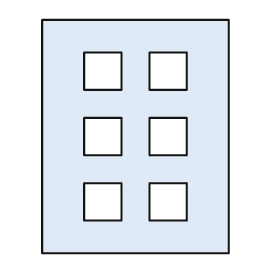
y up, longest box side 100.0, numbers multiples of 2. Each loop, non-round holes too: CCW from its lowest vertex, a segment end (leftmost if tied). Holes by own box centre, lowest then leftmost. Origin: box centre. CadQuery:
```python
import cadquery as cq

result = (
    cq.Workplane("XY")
    .moveTo(-40.0, -50.0)
    .lineTo(40.0, -50.0)
    .lineTo(40.0, 50.0)
    .lineTo(-40.0, 50.0)
    .close()
    .moveTo(-22.0, -36.0)
    .lineTo(-6.0, -36.0)
    .lineTo(-6.0, -20.0)
    .lineTo(-22.0, -20.0)
    .close()
    .moveTo(6.0, -36.0)
    .lineTo(22.0, -36.0)
    .lineTo(22.0, -20.0)
    .lineTo(6.0, -20.0)
    .close()
    .moveTo(-22.0, -8.0)
    .lineTo(-6.0, -8.0)
    .lineTo(-6.0, 8.0)
    .lineTo(-22.0, 8.0)
    .close()
    .moveTo(6.0, -8.0)
    .lineTo(22.0, -8.0)
    .lineTo(22.0, 8.0)
    .lineTo(6.0, 8.0)
    .close()
    .moveTo(-22.0, 20.0)
    .lineTo(-6.0, 20.0)
    .lineTo(-6.0, 36.0)
    .lineTo(-22.0, 36.0)
    .close()
    .moveTo(6.0, 20.0)
    .lineTo(22.0, 20.0)
    .lineTo(22.0, 36.0)
    .lineTo(6.0, 36.0)
    .close()
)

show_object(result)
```